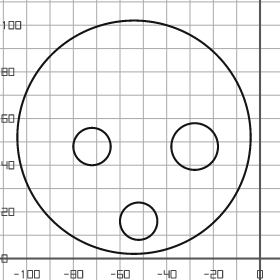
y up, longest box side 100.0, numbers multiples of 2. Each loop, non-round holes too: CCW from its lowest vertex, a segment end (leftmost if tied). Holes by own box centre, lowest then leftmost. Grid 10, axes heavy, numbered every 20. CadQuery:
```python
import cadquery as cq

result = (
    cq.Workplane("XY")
    .moveTo(-54.0, 52.0)
    .circle(50.0)
    .moveTo(-52.0, 16.0)
    .circle(8.0)
    .moveTo(-72.0, 48.0)
    .circle(8.0)
    .moveTo(-28.0, 48.0)
    .circle(10.0)
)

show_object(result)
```